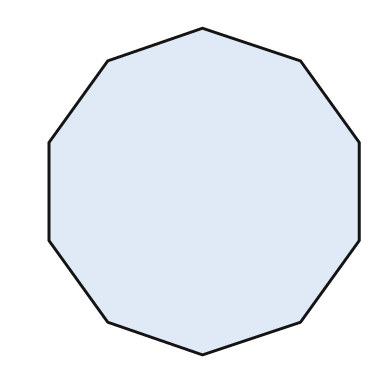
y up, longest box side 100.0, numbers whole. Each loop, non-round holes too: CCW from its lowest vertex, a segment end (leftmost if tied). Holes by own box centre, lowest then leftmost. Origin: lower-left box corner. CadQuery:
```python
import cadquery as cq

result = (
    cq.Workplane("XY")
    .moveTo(47.0, 0.0)
    .lineTo(77.0, 10.0)
    .lineTo(95.0, 35.0)
    .lineTo(95.0, 65.0)
    .lineTo(77.0, 90.0)
    .lineTo(47.0, 100.0)
    .lineTo(18.0, 90.0)
    .lineTo(0.0, 65.0)
    .lineTo(0.0, 35.0)
    .lineTo(18.0, 10.0)
    .close()
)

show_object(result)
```